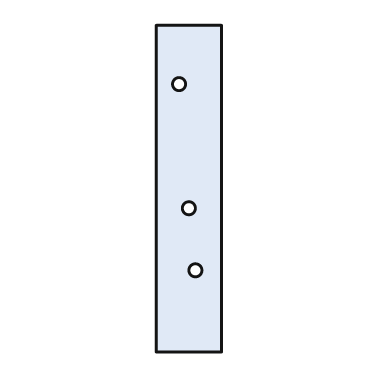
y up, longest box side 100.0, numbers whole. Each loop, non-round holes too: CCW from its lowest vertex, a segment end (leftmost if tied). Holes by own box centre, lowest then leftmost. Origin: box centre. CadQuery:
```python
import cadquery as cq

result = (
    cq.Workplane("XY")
    .moveTo(-10.0, -50.0)
    .lineTo(10.0, -50.0)
    .lineTo(10.0, 50.0)
    .lineTo(-10.0, 50.0)
    .close()
    .moveTo(2.0, -25.0)
    .circle(2.0)
    .moveTo(0.0, -6.0)
    .circle(2.0)
    .moveTo(-3.0, 32.0)
    .circle(2.0)
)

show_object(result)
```